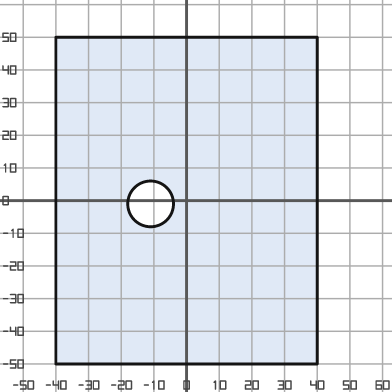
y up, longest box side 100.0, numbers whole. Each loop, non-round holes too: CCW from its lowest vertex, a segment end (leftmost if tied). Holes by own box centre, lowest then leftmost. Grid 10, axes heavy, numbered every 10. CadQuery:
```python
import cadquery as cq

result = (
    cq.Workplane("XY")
    .moveTo(-40.0, -50.0)
    .lineTo(40.0, -50.0)
    .lineTo(40.0, 50.0)
    .lineTo(-40.0, 50.0)
    .close()
    .moveTo(-11.0, -1.0)
    .circle(7.0)
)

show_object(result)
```